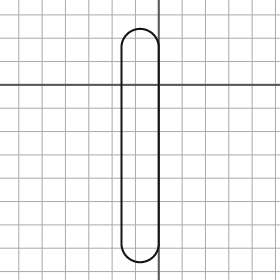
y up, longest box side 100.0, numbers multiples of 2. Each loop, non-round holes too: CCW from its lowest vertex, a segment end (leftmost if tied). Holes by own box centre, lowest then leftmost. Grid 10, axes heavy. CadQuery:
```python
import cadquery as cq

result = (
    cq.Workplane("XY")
    .moveTo(-16.0, -68.0)
    .threePointArc((-8.0, -76.0), (0.0, -68.0))
    .lineTo(0.0, 16.0)
    .threePointArc((-8.0, 24.0), (-16.0, 16.0))
    .close()
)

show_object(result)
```